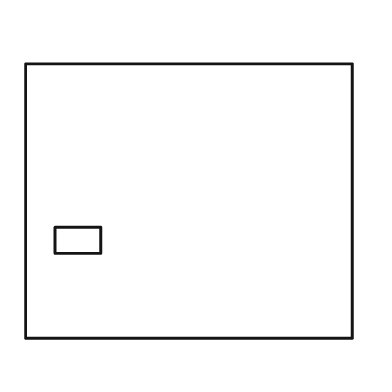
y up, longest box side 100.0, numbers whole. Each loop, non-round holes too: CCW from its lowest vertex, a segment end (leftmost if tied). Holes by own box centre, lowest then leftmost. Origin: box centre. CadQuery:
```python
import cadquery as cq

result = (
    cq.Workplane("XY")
    .moveTo(-50.0, -42.0)
    .lineTo(50.0, -42.0)
    .lineTo(50.0, 42.0)
    .lineTo(-50.0, 42.0)
    .close()
    .moveTo(-41.0, -16.0)
    .lineTo(-27.0, -16.0)
    .lineTo(-27.0, -8.0)
    .lineTo(-41.0, -8.0)
    .close()
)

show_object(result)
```